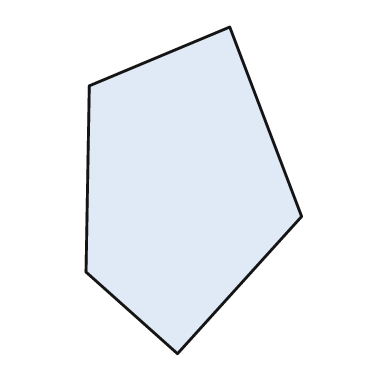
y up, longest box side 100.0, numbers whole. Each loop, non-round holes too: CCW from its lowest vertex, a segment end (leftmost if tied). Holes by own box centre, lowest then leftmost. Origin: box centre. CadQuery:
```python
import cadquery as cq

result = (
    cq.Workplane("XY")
    .moveTo(-5.0, -50.0)
    .lineTo(33.0, -8.0)
    .lineTo(11.0, 50.0)
    .lineTo(-32.0, 32.0)
    .lineTo(-33.0, -25.0)
    .close()
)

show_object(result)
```